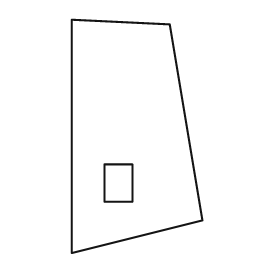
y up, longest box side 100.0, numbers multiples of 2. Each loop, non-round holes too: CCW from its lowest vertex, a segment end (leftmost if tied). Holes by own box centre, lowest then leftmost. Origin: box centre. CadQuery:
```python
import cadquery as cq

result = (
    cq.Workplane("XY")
    .moveTo(-28.0, -50.0)
    .lineTo(28.0, -36.0)
    .lineTo(14.0, 48.0)
    .lineTo(-28.0, 50.0)
    .close()
    .moveTo(-14.0, -28.0)
    .lineTo(-2.0, -28.0)
    .lineTo(-2.0, -12.0)
    .lineTo(-14.0, -12.0)
    .close()
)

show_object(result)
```